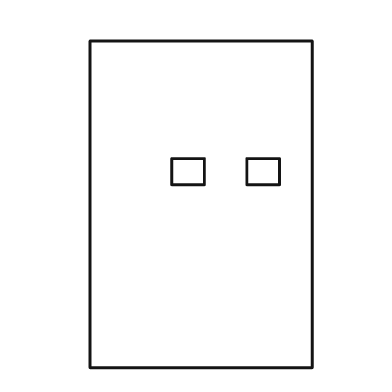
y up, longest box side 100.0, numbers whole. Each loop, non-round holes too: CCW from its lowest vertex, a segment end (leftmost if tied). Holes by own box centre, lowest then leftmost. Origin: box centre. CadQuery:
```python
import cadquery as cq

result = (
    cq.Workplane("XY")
    .moveTo(-34.0, -50.0)
    .lineTo(34.0, -50.0)
    .lineTo(34.0, 50.0)
    .lineTo(-34.0, 50.0)
    .close()
    .moveTo(-9.0, 6.0)
    .lineTo(1.0, 6.0)
    .lineTo(1.0, 14.0)
    .lineTo(-9.0, 14.0)
    .close()
    .moveTo(14.0, 6.0)
    .lineTo(24.0, 6.0)
    .lineTo(24.0, 14.0)
    .lineTo(14.0, 14.0)
    .close()
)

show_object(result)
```